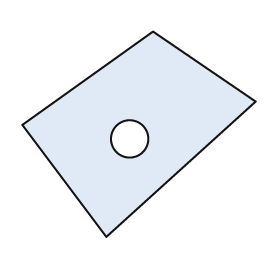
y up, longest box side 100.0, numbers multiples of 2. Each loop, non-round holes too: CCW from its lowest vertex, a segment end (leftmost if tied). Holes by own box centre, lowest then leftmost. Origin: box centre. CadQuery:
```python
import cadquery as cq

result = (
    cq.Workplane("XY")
    .moveTo(-14.0, -44.0)
    .lineTo(50.0, 14.0)
    .lineTo(6.0, 44.0)
    .lineTo(-50.0, 4.0)
    .close()
    .moveTo(-4.0, -2.0)
    .circle(8.0)
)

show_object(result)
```